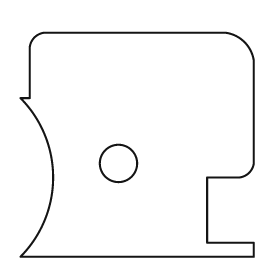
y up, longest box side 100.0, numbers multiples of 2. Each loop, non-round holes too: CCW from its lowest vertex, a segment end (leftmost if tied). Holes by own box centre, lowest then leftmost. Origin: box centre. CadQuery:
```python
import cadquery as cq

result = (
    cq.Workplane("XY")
    .moveTo(-50.0, -48.0)
    .lineTo(50.0, -48.0)
    .lineTo(50.0, -42.0)
    .lineTo(30.0, -42.0)
    .lineTo(30.0, -14.0)
    .lineTo(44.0, -14.0)
    .threePointArc((48.0, -12.0), (50.0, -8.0))
    .lineTo(50.0, 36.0)
    .threePointArc((46.0, 44.0), (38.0, 48.0))
    .lineTo(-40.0, 48.0)
    .threePointArc((-44.0, 46.0), (-46.0, 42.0))
    .lineTo(-46.0, 20.0)
    .lineTo(-50.0, 20.0)
    .threePointArc((-36.0, -14.0), (-50.0, -48.0))
    .close()
    .moveTo(-8.0, -8.0)
    .circle(8.0)
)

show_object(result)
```